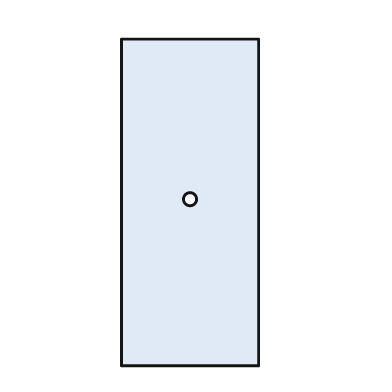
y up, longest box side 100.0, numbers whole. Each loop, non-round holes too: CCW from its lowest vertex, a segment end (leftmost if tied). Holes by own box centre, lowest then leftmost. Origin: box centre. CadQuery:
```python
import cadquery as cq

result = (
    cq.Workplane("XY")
    .moveTo(-21.0, -50.0)
    .lineTo(21.0, -50.0)
    .lineTo(21.0, 50.0)
    .lineTo(-21.0, 50.0)
    .close()
    .moveTo(0.0, 1.0)
    .circle(2.0)
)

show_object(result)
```